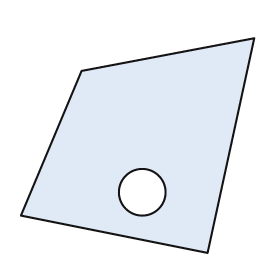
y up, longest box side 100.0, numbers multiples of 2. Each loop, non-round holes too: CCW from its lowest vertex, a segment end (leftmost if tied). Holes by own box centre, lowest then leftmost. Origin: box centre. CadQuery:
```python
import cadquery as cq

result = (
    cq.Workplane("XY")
    .moveTo(30.0, -46.0)
    .lineTo(50.0, 46.0)
    .lineTo(-24.0, 32.0)
    .lineTo(-50.0, -30.0)
    .close()
    .moveTo(2.0, -20.0)
    .circle(10.0)
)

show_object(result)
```